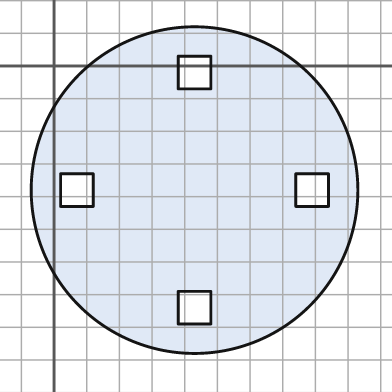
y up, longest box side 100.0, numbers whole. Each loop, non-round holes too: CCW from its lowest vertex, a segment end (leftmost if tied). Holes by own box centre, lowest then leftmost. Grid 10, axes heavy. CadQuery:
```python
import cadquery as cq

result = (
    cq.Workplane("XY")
    .moveTo(43.0, -38.0)
    .circle(50.0)
    .moveTo(38.0, -79.0)
    .lineTo(48.0, -79.0)
    .lineTo(48.0, -69.0)
    .lineTo(38.0, -69.0)
    .close()
    .moveTo(2.0, -43.0)
    .lineTo(12.0, -43.0)
    .lineTo(12.0, -33.0)
    .lineTo(2.0, -33.0)
    .close()
    .moveTo(74.0, -43.0)
    .lineTo(84.0, -43.0)
    .lineTo(84.0, -33.0)
    .lineTo(74.0, -33.0)
    .close()
    .moveTo(38.0, -7.0)
    .lineTo(48.0, -7.0)
    .lineTo(48.0, 3.0)
    .lineTo(38.0, 3.0)
    .close()
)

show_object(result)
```